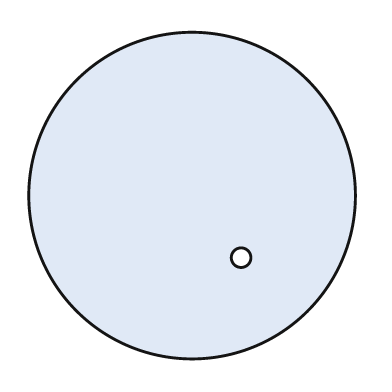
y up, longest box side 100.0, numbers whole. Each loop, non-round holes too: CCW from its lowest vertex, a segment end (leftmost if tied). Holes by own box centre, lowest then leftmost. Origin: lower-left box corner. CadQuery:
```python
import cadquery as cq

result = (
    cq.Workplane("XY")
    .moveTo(50.0, 50.0)
    .circle(50.0)
    .moveTo(65.0, 31.0)
    .circle(3.0)
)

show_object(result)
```